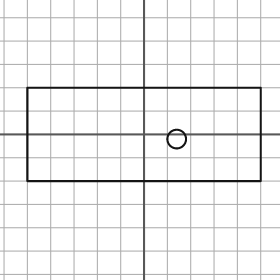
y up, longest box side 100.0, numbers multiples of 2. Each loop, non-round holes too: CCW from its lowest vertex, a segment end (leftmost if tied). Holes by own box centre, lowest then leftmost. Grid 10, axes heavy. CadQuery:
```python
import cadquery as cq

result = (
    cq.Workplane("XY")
    .moveTo(-50.0, -20.0)
    .lineTo(50.0, -20.0)
    .lineTo(50.0, 20.0)
    .lineTo(-50.0, 20.0)
    .close()
    .moveTo(14.0, -2.0)
    .circle(4.0)
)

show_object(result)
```